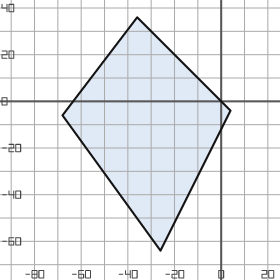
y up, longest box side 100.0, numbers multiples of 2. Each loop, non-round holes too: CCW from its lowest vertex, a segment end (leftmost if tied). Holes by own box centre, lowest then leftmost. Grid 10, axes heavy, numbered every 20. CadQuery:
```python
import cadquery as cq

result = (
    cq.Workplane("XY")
    .moveTo(-26.0, -64.0)
    .lineTo(4.0, -4.0)
    .lineTo(-36.0, 36.0)
    .lineTo(-68.0, -6.0)
    .close()
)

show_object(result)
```